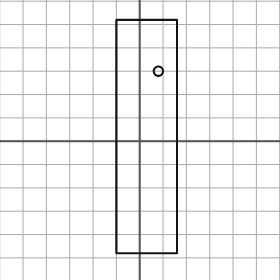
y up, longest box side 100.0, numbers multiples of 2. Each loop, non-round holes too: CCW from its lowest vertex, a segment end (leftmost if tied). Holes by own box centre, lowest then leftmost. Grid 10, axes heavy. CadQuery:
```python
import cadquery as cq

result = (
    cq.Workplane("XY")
    .moveTo(-10.0, -48.0)
    .lineTo(16.0, -48.0)
    .lineTo(16.0, 52.0)
    .lineTo(-10.0, 52.0)
    .close()
    .moveTo(8.0, 30.0)
    .circle(2.0)
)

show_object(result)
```